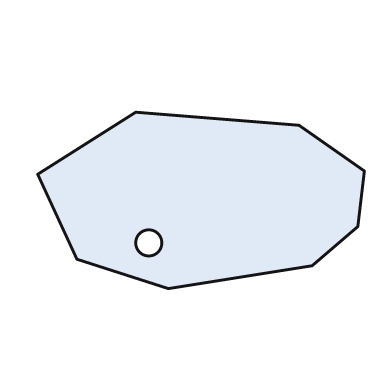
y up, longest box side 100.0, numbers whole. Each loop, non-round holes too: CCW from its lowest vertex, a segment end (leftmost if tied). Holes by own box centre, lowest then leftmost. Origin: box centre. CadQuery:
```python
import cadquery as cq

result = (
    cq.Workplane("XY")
    .moveTo(-10.0, -27.0)
    .lineTo(34.0, -20.0)
    .lineTo(48.0, -8.0)
    .lineTo(50.0, 9.0)
    .lineTo(30.0, 23.0)
    .lineTo(-20.0, 27.0)
    .lineTo(-50.0, 8.0)
    .lineTo(-38.0, -18.0)
    .close()
    .moveTo(-16.0, -13.0)
    .circle(4.0)
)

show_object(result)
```